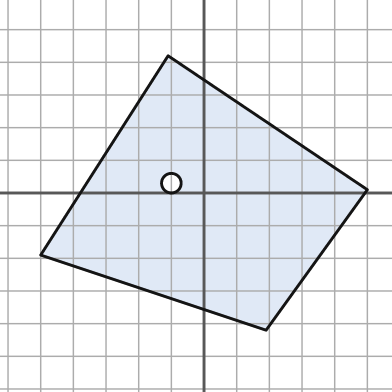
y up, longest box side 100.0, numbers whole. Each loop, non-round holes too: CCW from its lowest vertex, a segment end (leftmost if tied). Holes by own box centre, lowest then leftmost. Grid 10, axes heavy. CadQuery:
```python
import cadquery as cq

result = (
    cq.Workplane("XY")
    .moveTo(19.0, -42.0)
    .lineTo(50.0, 1.0)
    .lineTo(-11.0, 42.0)
    .lineTo(-50.0, -19.0)
    .close()
    .moveTo(-10.0, 3.0)
    .circle(3.0)
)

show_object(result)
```